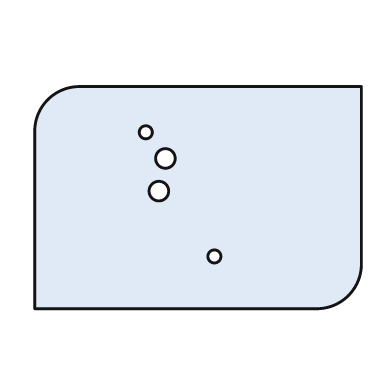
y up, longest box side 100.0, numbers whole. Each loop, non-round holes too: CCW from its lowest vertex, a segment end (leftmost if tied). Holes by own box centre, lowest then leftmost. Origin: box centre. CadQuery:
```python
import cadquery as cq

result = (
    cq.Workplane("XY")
    .moveTo(-50.0, -34.0)
    .lineTo(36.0, -34.0)
    .threePointArc((46.0, -30.0), (50.0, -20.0))
    .lineTo(50.0, 34.0)
    .lineTo(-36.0, 34.0)
    .threePointArc((-46.0, 30.0), (-50.0, 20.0))
    .close()
    .moveTo(5.0, -18.0)
    .circle(2.0)
    .moveTo(-12.0, 2.0)
    .circle(3.0)
    .moveTo(-10.0, 12.0)
    .circle(3.0)
    .moveTo(-16.0, 20.0)
    .circle(2.0)
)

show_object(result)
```